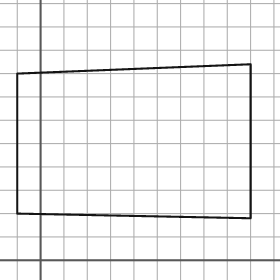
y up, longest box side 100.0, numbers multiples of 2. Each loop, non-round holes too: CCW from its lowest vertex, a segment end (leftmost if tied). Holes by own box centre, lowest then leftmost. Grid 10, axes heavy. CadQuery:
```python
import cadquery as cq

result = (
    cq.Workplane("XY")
    .moveTo(90.0, 18.0)
    .lineTo(90.0, 84.0)
    .lineTo(-10.0, 80.0)
    .lineTo(-10.0, 20.0)
    .close()
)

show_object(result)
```